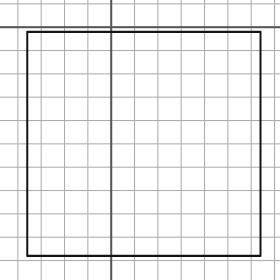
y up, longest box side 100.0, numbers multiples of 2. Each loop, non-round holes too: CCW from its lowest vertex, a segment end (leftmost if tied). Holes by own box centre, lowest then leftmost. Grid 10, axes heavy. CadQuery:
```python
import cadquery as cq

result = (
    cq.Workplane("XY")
    .moveTo(-36.0, -98.0)
    .lineTo(64.0, -98.0)
    .lineTo(64.0, -2.0)
    .lineTo(-36.0, -2.0)
    .close()
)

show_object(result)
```